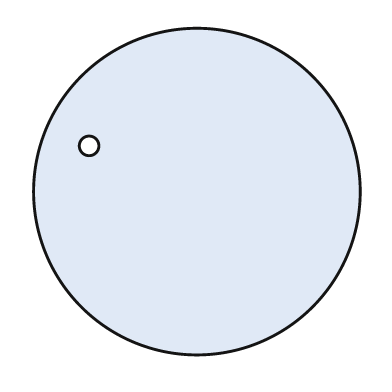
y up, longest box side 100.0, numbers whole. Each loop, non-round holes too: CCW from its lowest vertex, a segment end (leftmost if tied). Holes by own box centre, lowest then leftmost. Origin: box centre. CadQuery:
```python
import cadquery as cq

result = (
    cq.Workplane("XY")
    .moveTo(0.0, 0.0)
    .circle(50.0)
    .moveTo(-33.0, 14.0)
    .circle(3.0)
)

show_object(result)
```